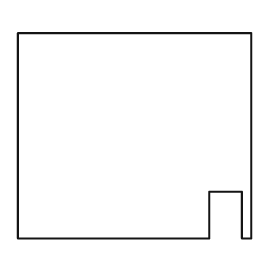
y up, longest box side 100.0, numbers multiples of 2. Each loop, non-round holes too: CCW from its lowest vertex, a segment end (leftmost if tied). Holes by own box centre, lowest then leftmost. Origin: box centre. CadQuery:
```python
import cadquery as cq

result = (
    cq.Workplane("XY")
    .moveTo(-50.0, -44.0)
    .lineTo(32.0, -44.0)
    .lineTo(32.0, -24.0)
    .lineTo(46.0, -24.0)
    .lineTo(46.0, -44.0)
    .lineTo(50.0, -44.0)
    .lineTo(50.0, 44.0)
    .lineTo(-50.0, 44.0)
    .close()
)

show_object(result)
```